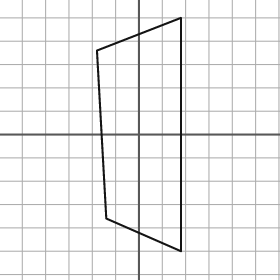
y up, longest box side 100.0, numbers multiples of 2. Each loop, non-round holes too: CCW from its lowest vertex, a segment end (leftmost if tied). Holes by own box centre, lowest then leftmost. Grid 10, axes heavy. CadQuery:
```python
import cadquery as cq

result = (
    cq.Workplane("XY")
    .moveTo(18.0, -50.0)
    .lineTo(18.0, 50.0)
    .lineTo(-18.0, 36.0)
    .lineTo(-14.0, -36.0)
    .close()
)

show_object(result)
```